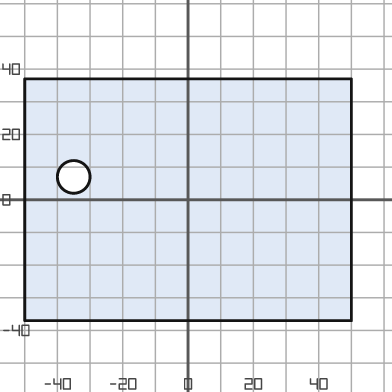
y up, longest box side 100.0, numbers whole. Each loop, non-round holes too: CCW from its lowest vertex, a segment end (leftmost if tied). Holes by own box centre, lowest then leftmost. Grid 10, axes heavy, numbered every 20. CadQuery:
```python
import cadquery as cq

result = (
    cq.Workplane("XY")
    .moveTo(-50.0, -37.0)
    .lineTo(50.0, -37.0)
    .lineTo(50.0, 37.0)
    .lineTo(-50.0, 37.0)
    .close()
    .moveTo(-35.0, 7.0)
    .circle(5.0)
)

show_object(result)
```